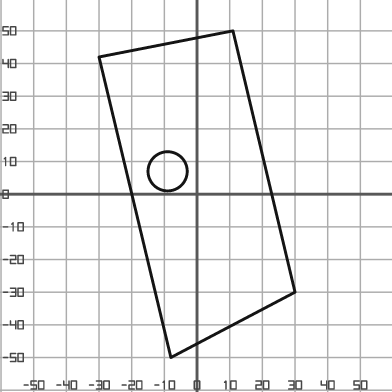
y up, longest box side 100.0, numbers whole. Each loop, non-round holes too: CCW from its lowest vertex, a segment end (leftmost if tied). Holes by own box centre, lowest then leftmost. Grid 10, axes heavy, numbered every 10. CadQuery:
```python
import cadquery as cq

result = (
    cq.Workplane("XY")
    .moveTo(-8.0, -50.0)
    .lineTo(30.0, -30.0)
    .lineTo(11.0, 50.0)
    .lineTo(-30.0, 42.0)
    .close()
    .moveTo(-9.0, 7.0)
    .circle(6.0)
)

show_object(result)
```